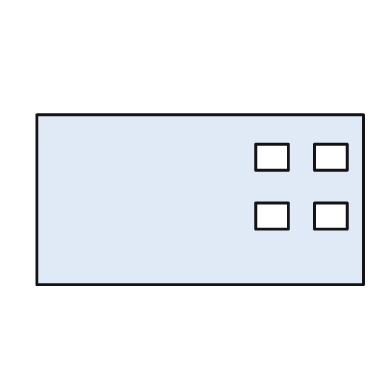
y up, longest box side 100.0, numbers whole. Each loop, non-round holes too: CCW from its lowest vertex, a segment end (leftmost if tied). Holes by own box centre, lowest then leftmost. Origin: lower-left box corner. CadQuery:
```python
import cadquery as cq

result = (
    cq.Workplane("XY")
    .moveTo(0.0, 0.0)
    .lineTo(100.0, 0.0)
    .lineTo(100.0, 52.0)
    .lineTo(0.0, 52.0)
    .close()
    .moveTo(67.0, 17.0)
    .lineTo(77.0, 17.0)
    .lineTo(77.0, 25.0)
    .lineTo(67.0, 25.0)
    .close()
    .moveTo(85.0, 17.0)
    .lineTo(95.0, 17.0)
    .lineTo(95.0, 25.0)
    .lineTo(85.0, 25.0)
    .close()
    .moveTo(67.0, 35.0)
    .lineTo(77.0, 35.0)
    .lineTo(77.0, 43.0)
    .lineTo(67.0, 43.0)
    .close()
    .moveTo(85.0, 35.0)
    .lineTo(95.0, 35.0)
    .lineTo(95.0, 43.0)
    .lineTo(85.0, 43.0)
    .close()
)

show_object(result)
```